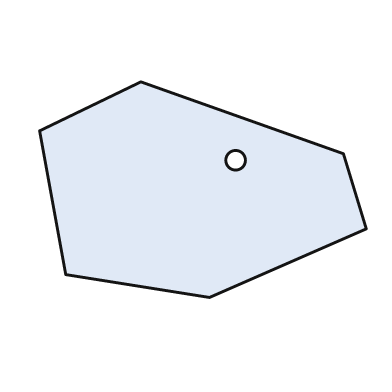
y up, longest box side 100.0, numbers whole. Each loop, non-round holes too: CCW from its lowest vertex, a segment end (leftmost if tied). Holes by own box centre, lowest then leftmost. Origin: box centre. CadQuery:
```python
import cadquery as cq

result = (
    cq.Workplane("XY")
    .moveTo(2.0, -33.0)
    .lineTo(50.0, -12.0)
    .lineTo(43.0, 11.0)
    .lineTo(-19.0, 33.0)
    .lineTo(-50.0, 18.0)
    .lineTo(-42.0, -26.0)
    .close()
    .moveTo(10.0, 9.0)
    .circle(3.0)
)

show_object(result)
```